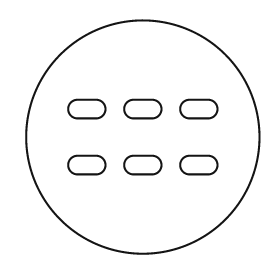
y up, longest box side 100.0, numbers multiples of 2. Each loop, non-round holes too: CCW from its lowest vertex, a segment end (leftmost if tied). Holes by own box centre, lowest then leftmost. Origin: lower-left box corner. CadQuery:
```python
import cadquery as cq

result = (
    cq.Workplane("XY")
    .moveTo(50.0, 50.0)
    .circle(50.0)
    .moveTo(22.0, 34.0)
    .lineTo(30.0, 34.0)
    .threePointArc((34.0, 38.0), (30.0, 42.0))
    .lineTo(22.0, 42.0)
    .threePointArc((18.0, 38.0), (22.0, 34.0))
    .close()
    .moveTo(46.0, 34.0)
    .lineTo(54.0, 34.0)
    .threePointArc((58.0, 38.0), (54.0, 42.0))
    .lineTo(46.0, 42.0)
    .threePointArc((42.0, 38.0), (46.0, 34.0))
    .close()
    .moveTo(70.0, 34.0)
    .lineTo(78.0, 34.0)
    .threePointArc((82.0, 38.0), (78.0, 42.0))
    .lineTo(70.0, 42.0)
    .threePointArc((66.0, 38.0), (70.0, 34.0))
    .close()
    .moveTo(22.0, 58.0)
    .lineTo(30.0, 58.0)
    .threePointArc((34.0, 62.0), (30.0, 66.0))
    .lineTo(22.0, 66.0)
    .threePointArc((18.0, 62.0), (22.0, 58.0))
    .close()
    .moveTo(46.0, 58.0)
    .lineTo(54.0, 58.0)
    .threePointArc((58.0, 62.0), (54.0, 66.0))
    .lineTo(46.0, 66.0)
    .threePointArc((42.0, 62.0), (46.0, 58.0))
    .close()
    .moveTo(70.0, 58.0)
    .lineTo(78.0, 58.0)
    .threePointArc((82.0, 62.0), (78.0, 66.0))
    .lineTo(70.0, 66.0)
    .threePointArc((66.0, 62.0), (70.0, 58.0))
    .close()
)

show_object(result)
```